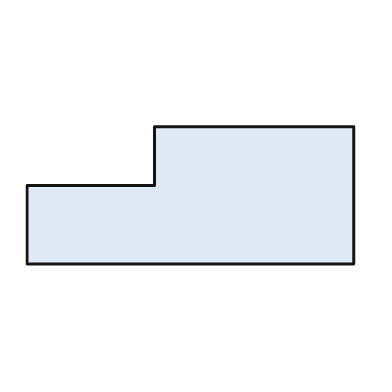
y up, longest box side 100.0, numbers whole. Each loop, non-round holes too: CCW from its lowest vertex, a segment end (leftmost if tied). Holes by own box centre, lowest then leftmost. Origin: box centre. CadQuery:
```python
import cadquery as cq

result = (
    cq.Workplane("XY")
    .moveTo(-50.0, -21.0)
    .lineTo(50.0, -21.0)
    .lineTo(50.0, 21.0)
    .lineTo(-11.0, 21.0)
    .lineTo(-11.0, 3.0)
    .lineTo(-50.0, 3.0)
    .close()
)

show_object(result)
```